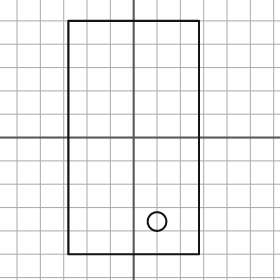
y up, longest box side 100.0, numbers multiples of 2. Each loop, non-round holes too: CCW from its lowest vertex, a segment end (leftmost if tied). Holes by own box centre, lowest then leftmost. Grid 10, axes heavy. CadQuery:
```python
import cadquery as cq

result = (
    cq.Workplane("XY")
    .moveTo(-28.0, -50.0)
    .lineTo(28.0, -50.0)
    .lineTo(28.0, 50.0)
    .lineTo(-28.0, 50.0)
    .close()
    .moveTo(10.0, -36.0)
    .circle(4.0)
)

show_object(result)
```